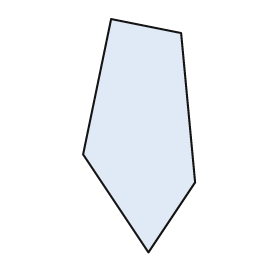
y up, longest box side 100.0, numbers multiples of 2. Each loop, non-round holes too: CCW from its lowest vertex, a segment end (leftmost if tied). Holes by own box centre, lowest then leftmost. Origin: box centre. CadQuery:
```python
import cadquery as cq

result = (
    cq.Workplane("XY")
    .moveTo(4.0, -50.0)
    .lineTo(24.0, -20.0)
    .lineTo(18.0, 44.0)
    .lineTo(-12.0, 50.0)
    .lineTo(-24.0, -8.0)
    .close()
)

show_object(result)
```